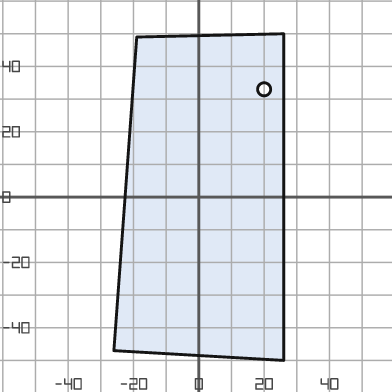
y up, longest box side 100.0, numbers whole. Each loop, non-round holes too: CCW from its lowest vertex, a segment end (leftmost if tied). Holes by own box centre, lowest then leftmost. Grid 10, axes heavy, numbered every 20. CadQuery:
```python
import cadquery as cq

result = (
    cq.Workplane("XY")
    .moveTo(26.0, -50.0)
    .lineTo(26.0, 50.0)
    .lineTo(-19.0, 49.0)
    .lineTo(-26.0, -47.0)
    .close()
    .moveTo(20.0, 33.0)
    .circle(2.0)
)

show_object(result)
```